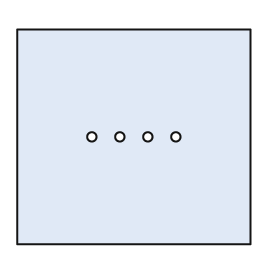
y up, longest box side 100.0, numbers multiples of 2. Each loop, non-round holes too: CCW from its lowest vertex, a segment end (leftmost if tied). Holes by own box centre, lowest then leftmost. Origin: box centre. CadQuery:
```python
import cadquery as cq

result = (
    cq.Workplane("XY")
    .moveTo(-50.0, -46.0)
    .lineTo(50.0, -46.0)
    .lineTo(50.0, 46.0)
    .lineTo(-50.0, 46.0)
    .close()
    .moveTo(-18.0, 0.0)
    .circle(2.0)
    .moveTo(-6.0, 0.0)
    .circle(2.0)
    .moveTo(6.0, 0.0)
    .circle(2.0)
    .moveTo(18.0, 0.0)
    .circle(2.0)
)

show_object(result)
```